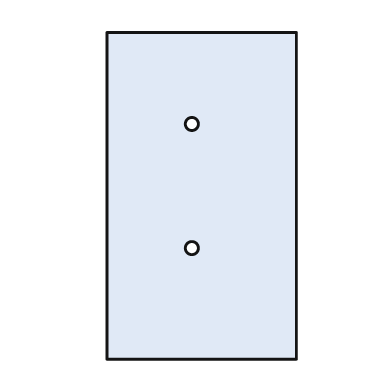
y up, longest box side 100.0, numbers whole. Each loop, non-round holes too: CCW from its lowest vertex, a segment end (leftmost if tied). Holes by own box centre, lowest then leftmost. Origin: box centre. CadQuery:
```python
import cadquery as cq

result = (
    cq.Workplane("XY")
    .moveTo(-29.0, -50.0)
    .lineTo(29.0, -50.0)
    .lineTo(29.0, 50.0)
    .lineTo(-29.0, 50.0)
    .close()
    .moveTo(-3.0, -16.0)
    .circle(2.0)
    .moveTo(-3.0, 22.0)
    .circle(2.0)
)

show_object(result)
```